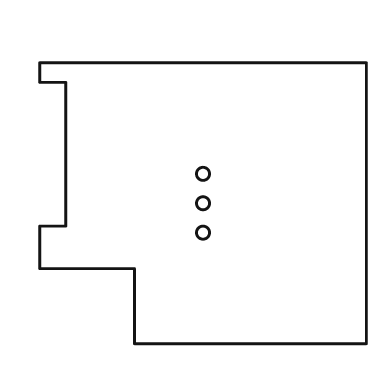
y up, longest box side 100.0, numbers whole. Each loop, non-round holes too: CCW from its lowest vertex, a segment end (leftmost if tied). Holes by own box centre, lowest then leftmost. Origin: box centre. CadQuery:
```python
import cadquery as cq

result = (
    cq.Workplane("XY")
    .moveTo(-21.0, -43.0)
    .lineTo(50.0, -43.0)
    .lineTo(50.0, 43.0)
    .lineTo(-50.0, 43.0)
    .lineTo(-50.0, 37.0)
    .lineTo(-42.0, 37.0)
    .lineTo(-42.0, -7.0)
    .lineTo(-50.0, -7.0)
    .lineTo(-50.0, -20.0)
    .lineTo(-21.0, -20.0)
    .close()
    .moveTo(0.0, -9.0)
    .circle(2.0)
    .moveTo(0.0, 0.0)
    .circle(2.0)
    .moveTo(0.0, 9.0)
    .circle(2.0)
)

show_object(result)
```